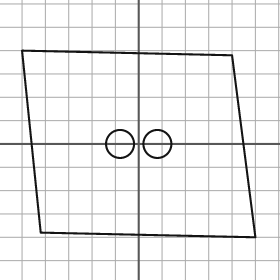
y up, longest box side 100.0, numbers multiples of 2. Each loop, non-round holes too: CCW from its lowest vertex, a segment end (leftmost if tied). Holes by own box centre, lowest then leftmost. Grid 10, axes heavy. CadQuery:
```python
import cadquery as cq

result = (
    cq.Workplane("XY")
    .moveTo(50.0, -40.0)
    .lineTo(40.0, 38.0)
    .lineTo(-50.0, 40.0)
    .lineTo(-42.0, -38.0)
    .close()
    .moveTo(-8.0, 0.0)
    .circle(6.0)
    .moveTo(8.0, 0.0)
    .circle(6.0)
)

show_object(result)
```